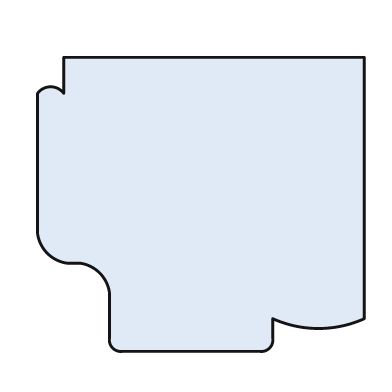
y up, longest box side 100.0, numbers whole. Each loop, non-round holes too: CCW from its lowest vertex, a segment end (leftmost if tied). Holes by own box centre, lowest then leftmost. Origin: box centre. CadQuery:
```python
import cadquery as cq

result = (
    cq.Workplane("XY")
    .moveTo(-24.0, -45.0)
    .lineTo(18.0, -45.0)
    .threePointArc((21.0, -44.0), (22.0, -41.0))
    .lineTo(22.0, -35.0)
    .threePointArc((36.0, -38.0), (50.0, -35.0))
    .lineTo(50.0, 45.0)
    .lineTo(-42.0, 45.0)
    .lineTo(-42.0, 34.0)
    .threePointArc((-46.0, 36.0), (-50.0, 34.0))
    .lineTo(-50.0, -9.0)
    .threePointArc((-47.0, -15.0), (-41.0, -18.0))
    .lineTo(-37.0, -18.0)
    .threePointArc((-31.0, -21.0), (-28.0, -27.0))
    .lineTo(-28.0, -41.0)
    .threePointArc((-27.0, -44.0), (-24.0, -45.0))
    .close()
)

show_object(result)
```